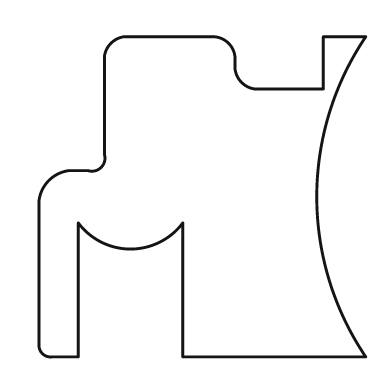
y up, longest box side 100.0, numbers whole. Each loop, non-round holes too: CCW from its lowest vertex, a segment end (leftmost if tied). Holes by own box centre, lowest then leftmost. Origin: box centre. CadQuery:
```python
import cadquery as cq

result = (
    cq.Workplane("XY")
    .moveTo(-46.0, -49.0)
    .lineTo(-38.0, -49.0)
    .lineTo(-38.0, -8.0)
    .threePointArc((-22.0, -16.0), (-6.0, -8.0))
    .lineTo(-6.0, -49.0)
    .lineTo(50.0, -49.0)
    .threePointArc((35.0, 0.0), (50.0, 49.0))
    .lineTo(37.0, 49.0)
    .lineTo(37.0, 33.0)
    .lineTo(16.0, 33.0)
    .threePointArc((12.0, 35.0), (10.0, 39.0))
    .lineTo(10.0, 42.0)
    .threePointArc((8.0, 47.0), (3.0, 49.0))
    .lineTo(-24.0, 49.0)
    .threePointArc((-28.0, 47.0), (-30.0, 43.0))
    .lineTo(-30.0, 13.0)
    .threePointArc((-31.0, 9.0), (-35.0, 8.0))
    .lineTo(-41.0, 8.0)
    .threePointArc((-47.0, 5.0), (-50.0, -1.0))
    .lineTo(-50.0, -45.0)
    .threePointArc((-49.0, -48.0), (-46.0, -49.0))
    .close()
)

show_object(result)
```